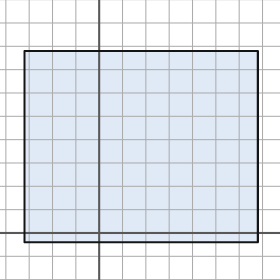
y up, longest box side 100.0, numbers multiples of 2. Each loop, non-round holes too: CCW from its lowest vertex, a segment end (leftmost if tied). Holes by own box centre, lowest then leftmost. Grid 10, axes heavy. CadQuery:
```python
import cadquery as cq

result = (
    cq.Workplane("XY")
    .moveTo(-32.0, -4.0)
    .lineTo(68.0, -4.0)
    .lineTo(68.0, 78.0)
    .lineTo(-32.0, 78.0)
    .close()
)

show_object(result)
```